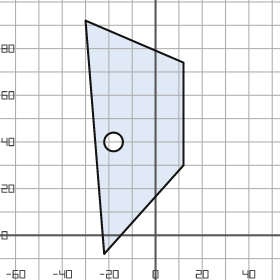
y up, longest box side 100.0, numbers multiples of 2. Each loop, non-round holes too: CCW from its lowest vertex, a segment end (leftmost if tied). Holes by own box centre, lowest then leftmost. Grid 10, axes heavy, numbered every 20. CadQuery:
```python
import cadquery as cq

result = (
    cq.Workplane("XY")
    .moveTo(-22.0, -8.0)
    .lineTo(12.0, 30.0)
    .lineTo(12.0, 74.0)
    .lineTo(-30.0, 92.0)
    .close()
    .moveTo(-18.0, 40.0)
    .circle(4.0)
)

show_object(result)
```